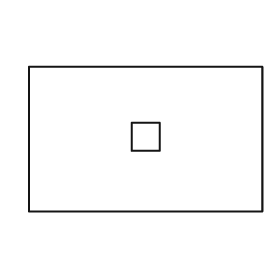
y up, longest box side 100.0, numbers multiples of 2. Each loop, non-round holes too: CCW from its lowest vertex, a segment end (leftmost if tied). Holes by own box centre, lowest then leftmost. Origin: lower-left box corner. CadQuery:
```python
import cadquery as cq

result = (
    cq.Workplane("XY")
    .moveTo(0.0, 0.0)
    .lineTo(100.0, 0.0)
    .lineTo(100.0, 62.0)
    .lineTo(0.0, 62.0)
    .close()
    .moveTo(44.0, 26.0)
    .lineTo(56.0, 26.0)
    .lineTo(56.0, 38.0)
    .lineTo(44.0, 38.0)
    .close()
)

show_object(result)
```